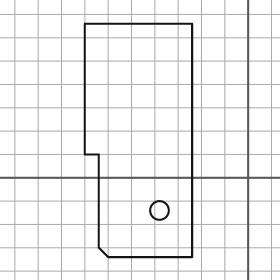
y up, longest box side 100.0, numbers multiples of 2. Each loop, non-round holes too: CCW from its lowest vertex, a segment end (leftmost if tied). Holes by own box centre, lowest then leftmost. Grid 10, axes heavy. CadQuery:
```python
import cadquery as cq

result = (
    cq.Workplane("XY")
    .moveTo(-60.0, -34.0)
    .lineTo(-24.0, -34.0)
    .lineTo(-24.0, 66.0)
    .lineTo(-70.0, 66.0)
    .lineTo(-70.0, 10.0)
    .lineTo(-64.0, 10.0)
    .lineTo(-64.0, -30.0)
    .close()
    .moveTo(-38.0, -14.0)
    .circle(4.0)
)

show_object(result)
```